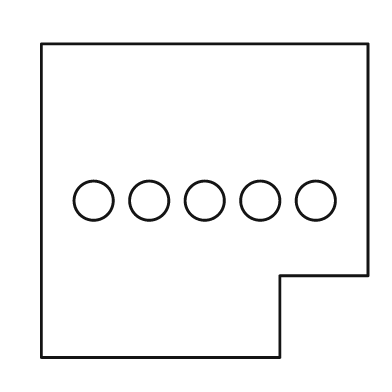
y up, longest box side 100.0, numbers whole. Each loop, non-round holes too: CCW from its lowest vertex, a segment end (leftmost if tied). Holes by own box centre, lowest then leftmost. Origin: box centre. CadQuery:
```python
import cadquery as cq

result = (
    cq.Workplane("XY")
    .moveTo(-50.0, -48.0)
    .lineTo(23.0, -48.0)
    .lineTo(23.0, -23.0)
    .lineTo(50.0, -23.0)
    .lineTo(50.0, 48.0)
    .lineTo(-50.0, 48.0)
    .close()
    .moveTo(-34.0, 0.0)
    .circle(6.0)
    .moveTo(-17.0, 0.0)
    .circle(6.0)
    .moveTo(0.0, 0.0)
    .circle(6.0)
    .moveTo(17.0, 0.0)
    .circle(6.0)
    .moveTo(34.0, 0.0)
    .circle(6.0)
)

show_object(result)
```